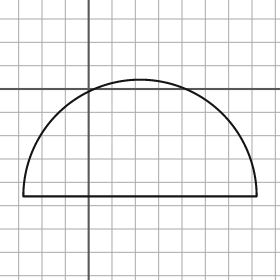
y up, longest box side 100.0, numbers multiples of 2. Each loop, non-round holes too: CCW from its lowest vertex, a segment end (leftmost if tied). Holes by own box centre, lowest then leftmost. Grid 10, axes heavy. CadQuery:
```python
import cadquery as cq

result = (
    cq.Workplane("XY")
    .moveTo(-28.0, -46.0)
    .lineTo(72.0, -46.0)
    .threePointArc((22.0, 4.0), (-28.0, -46.0))
    .close()
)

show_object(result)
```